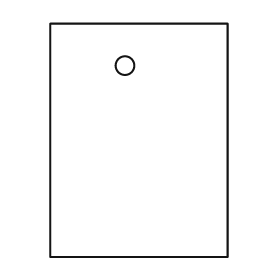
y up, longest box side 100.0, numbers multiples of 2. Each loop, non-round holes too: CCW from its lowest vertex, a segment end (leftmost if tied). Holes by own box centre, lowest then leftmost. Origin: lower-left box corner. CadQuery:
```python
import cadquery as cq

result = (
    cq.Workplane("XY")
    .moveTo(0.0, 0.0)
    .lineTo(76.0, 0.0)
    .lineTo(76.0, 100.0)
    .lineTo(0.0, 100.0)
    .close()
    .moveTo(32.0, 82.0)
    .circle(4.0)
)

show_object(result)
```